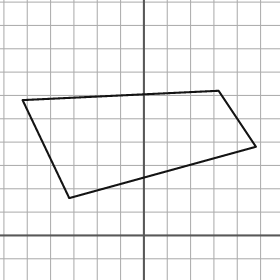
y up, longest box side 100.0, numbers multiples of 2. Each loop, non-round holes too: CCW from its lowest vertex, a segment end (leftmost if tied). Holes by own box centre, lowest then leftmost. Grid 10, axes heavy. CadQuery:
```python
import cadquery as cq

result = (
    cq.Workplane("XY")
    .moveTo(-32.0, 16.0)
    .lineTo(48.0, 38.0)
    .lineTo(32.0, 62.0)
    .lineTo(-52.0, 58.0)
    .close()
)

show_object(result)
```